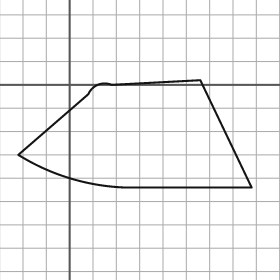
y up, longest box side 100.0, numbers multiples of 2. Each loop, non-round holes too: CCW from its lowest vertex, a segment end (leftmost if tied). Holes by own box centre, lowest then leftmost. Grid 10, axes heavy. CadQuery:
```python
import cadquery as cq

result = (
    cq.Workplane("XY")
    .moveTo(24.0, -44.0)
    .lineTo(78.0, -44.0)
    .lineTo(56.0, 2.0)
    .lineTo(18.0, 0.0)
    .threePointArc((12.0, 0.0), (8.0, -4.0))
    .lineTo(-22.0, -30.0)
    .threePointArc((0.0, -40.0), (24.0, -44.0))
    .close()
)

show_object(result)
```